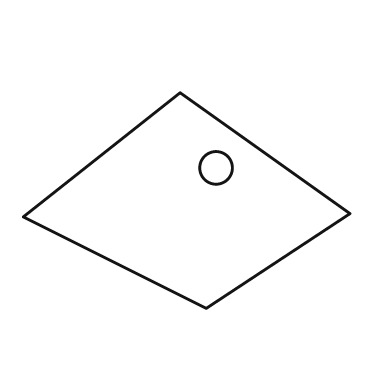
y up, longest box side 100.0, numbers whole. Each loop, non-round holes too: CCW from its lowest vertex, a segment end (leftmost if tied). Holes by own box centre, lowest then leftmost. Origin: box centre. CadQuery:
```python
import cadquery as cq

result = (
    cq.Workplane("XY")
    .moveTo(6.0, -33.0)
    .lineTo(50.0, -4.0)
    .lineTo(-2.0, 33.0)
    .lineTo(-50.0, -5.0)
    .close()
    .moveTo(9.0, 10.0)
    .circle(5.0)
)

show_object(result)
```